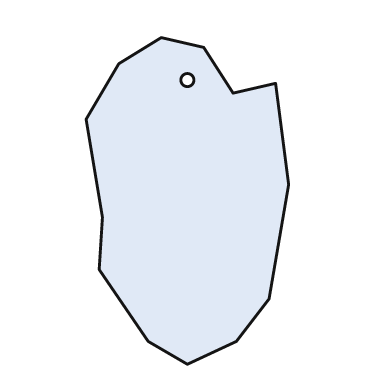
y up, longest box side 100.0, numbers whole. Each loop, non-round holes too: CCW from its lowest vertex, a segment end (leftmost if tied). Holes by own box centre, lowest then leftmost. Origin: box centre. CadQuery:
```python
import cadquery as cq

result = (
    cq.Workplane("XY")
    .moveTo(0.0, -50.0)
    .lineTo(15.0, -43.0)
    .lineTo(25.0, -30.0)
    .lineTo(31.0, 5.0)
    .lineTo(27.0, 36.0)
    .lineTo(14.0, 33.0)
    .lineTo(5.0, 47.0)
    .lineTo(-8.0, 50.0)
    .lineTo(-21.0, 42.0)
    .lineTo(-31.0, 25.0)
    .lineTo(-26.0, -5.0)
    .lineTo(-27.0, -21.0)
    .lineTo(-12.0, -43.0)
    .close()
    .moveTo(0.0, 37.0)
    .circle(2.0)
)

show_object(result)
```